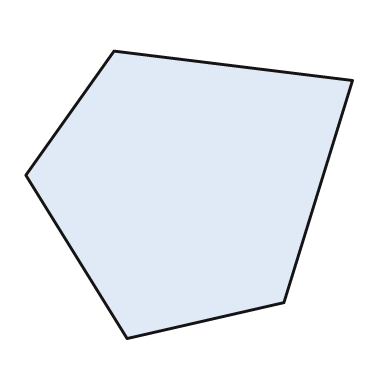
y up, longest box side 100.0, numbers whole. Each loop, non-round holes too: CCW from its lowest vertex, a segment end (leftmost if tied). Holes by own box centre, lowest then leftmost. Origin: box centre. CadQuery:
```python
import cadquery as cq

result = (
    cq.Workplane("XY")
    .moveTo(-19.0, -44.0)
    .lineTo(29.0, -33.0)
    .lineTo(50.0, 35.0)
    .lineTo(-23.0, 44.0)
    .lineTo(-50.0, 6.0)
    .close()
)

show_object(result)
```